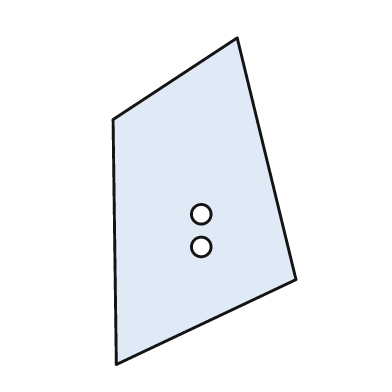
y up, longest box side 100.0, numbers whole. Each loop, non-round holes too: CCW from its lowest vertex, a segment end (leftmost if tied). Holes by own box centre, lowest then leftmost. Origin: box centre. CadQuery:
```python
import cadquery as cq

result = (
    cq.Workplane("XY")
    .moveTo(-27.0, -50.0)
    .lineTo(28.0, -24.0)
    .lineTo(10.0, 50.0)
    .lineTo(-28.0, 25.0)
    .close()
    .moveTo(-1.0, -14.0)
    .circle(3.0)
    .moveTo(-1.0, -4.0)
    .circle(3.0)
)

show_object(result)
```